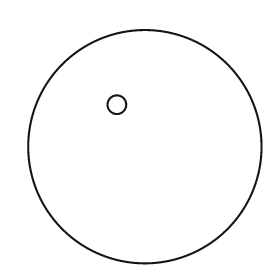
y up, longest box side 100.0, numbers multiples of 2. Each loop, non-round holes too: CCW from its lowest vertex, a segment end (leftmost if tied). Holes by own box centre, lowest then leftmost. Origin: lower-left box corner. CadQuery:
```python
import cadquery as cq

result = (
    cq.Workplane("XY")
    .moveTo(50.0, 50.0)
    .circle(50.0)
    .moveTo(38.0, 68.0)
    .circle(4.0)
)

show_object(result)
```